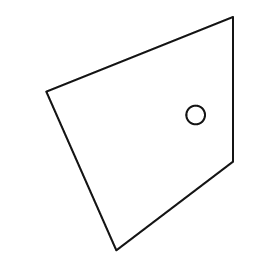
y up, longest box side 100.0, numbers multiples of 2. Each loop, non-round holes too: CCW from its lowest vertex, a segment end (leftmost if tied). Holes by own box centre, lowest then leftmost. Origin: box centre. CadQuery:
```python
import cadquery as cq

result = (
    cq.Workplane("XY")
    .moveTo(-10.0, -50.0)
    .lineTo(40.0, -12.0)
    .lineTo(40.0, 50.0)
    .lineTo(-40.0, 18.0)
    .close()
    .moveTo(24.0, 8.0)
    .circle(4.0)
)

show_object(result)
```